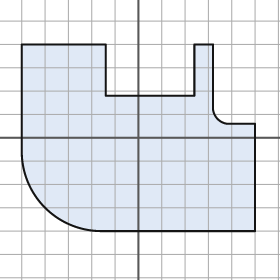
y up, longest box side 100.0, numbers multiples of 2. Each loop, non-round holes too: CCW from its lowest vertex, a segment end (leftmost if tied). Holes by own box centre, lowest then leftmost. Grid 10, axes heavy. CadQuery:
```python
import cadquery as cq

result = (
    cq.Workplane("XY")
    .moveTo(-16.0, -40.0)
    .lineTo(50.0, -40.0)
    .lineTo(50.0, 6.0)
    .lineTo(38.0, 6.0)
    .threePointArc((34.0, 8.0), (32.0, 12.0))
    .lineTo(32.0, 40.0)
    .lineTo(24.0, 40.0)
    .lineTo(24.0, 18.0)
    .lineTo(-14.0, 18.0)
    .lineTo(-14.0, 40.0)
    .lineTo(-50.0, 40.0)
    .lineTo(-50.0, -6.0)
    .threePointArc((-40.0, -30.0), (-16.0, -40.0))
    .close()
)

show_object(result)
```